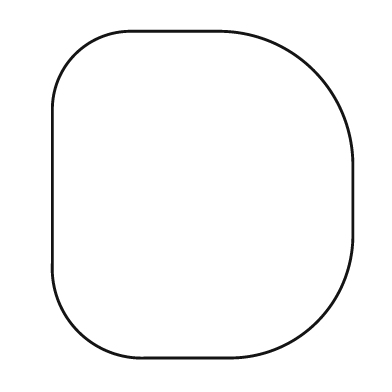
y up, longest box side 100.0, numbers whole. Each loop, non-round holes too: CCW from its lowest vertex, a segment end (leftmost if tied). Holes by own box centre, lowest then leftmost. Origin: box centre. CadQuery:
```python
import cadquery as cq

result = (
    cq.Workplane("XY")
    .moveTo(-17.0, -50.0)
    .lineTo(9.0, -50.0)
    .threePointArc((35.0, -39.0), (46.0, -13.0))
    .lineTo(46.0, 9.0)
    .threePointArc((34.0, 38.0), (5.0, 50.0))
    .lineTo(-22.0, 50.0)
    .threePointArc((-39.0, 43.0), (-46.0, 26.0))
    .lineTo(-46.0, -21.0)
    .threePointArc((-38.0, -42.0), (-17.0, -50.0))
    .close()
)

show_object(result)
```